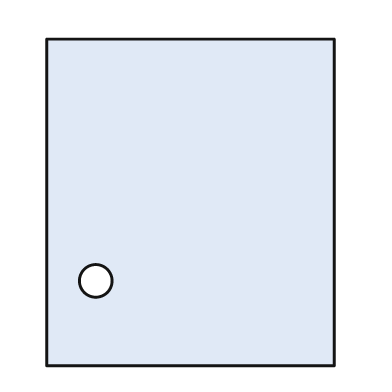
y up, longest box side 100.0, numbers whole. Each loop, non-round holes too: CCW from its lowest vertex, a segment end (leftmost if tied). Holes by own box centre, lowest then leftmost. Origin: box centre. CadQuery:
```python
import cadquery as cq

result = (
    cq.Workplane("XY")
    .moveTo(-44.0, -50.0)
    .lineTo(44.0, -50.0)
    .lineTo(44.0, 50.0)
    .lineTo(-44.0, 50.0)
    .close()
    .moveTo(-29.0, -24.0)
    .circle(5.0)
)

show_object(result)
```